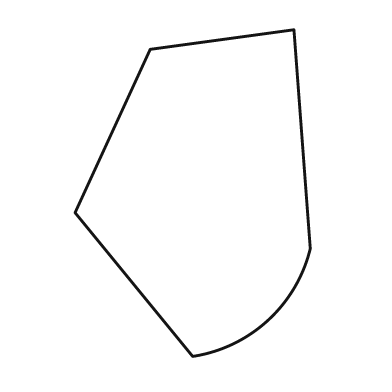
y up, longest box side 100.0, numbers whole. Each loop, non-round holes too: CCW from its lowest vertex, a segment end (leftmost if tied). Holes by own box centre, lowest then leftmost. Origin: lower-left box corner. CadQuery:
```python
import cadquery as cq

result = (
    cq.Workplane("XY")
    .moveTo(36.0, 0.0)
    .threePointArc((59.0, 11.0), (72.0, 33.0))
    .lineTo(67.0, 100.0)
    .lineTo(23.0, 94.0)
    .lineTo(0.0, 44.0)
    .close()
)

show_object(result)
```